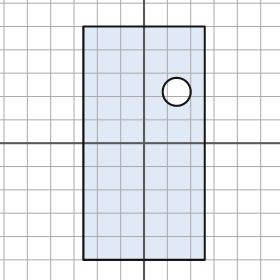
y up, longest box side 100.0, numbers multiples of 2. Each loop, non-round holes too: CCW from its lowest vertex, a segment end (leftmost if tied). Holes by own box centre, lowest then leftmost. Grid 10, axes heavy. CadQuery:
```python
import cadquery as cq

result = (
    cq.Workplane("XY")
    .moveTo(-26.0, -50.0)
    .lineTo(26.0, -50.0)
    .lineTo(26.0, 50.0)
    .lineTo(-26.0, 50.0)
    .close()
    .moveTo(14.0, 22.0)
    .circle(6.0)
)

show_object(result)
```